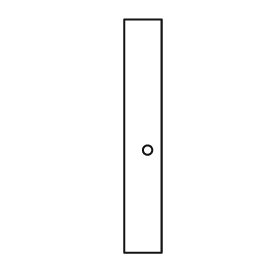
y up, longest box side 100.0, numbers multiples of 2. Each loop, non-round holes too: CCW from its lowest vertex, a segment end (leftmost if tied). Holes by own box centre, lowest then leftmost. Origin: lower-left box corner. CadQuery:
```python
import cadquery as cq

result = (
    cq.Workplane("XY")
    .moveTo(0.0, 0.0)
    .lineTo(16.0, 0.0)
    .lineTo(16.0, 100.0)
    .lineTo(0.0, 100.0)
    .close()
    .moveTo(10.0, 44.0)
    .circle(2.0)
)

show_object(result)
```